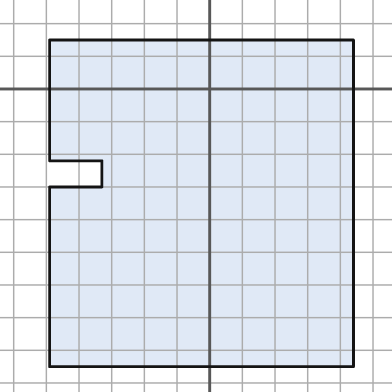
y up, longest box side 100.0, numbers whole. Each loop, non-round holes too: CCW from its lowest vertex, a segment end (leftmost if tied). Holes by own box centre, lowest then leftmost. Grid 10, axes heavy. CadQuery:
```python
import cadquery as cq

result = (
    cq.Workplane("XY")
    .moveTo(-49.0, -85.0)
    .lineTo(44.0, -85.0)
    .lineTo(44.0, 15.0)
    .lineTo(-49.0, 15.0)
    .lineTo(-49.0, -22.0)
    .lineTo(-33.0, -22.0)
    .lineTo(-33.0, -30.0)
    .lineTo(-49.0, -30.0)
    .close()
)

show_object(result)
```